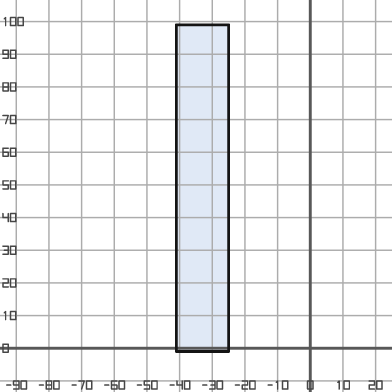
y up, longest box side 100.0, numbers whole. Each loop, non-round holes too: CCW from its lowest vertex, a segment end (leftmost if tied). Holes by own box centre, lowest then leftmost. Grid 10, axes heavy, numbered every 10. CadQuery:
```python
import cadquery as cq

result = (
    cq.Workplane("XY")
    .moveTo(-41.0, -1.0)
    .lineTo(-25.0, -1.0)
    .lineTo(-25.0, 99.0)
    .lineTo(-41.0, 99.0)
    .close()
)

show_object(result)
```